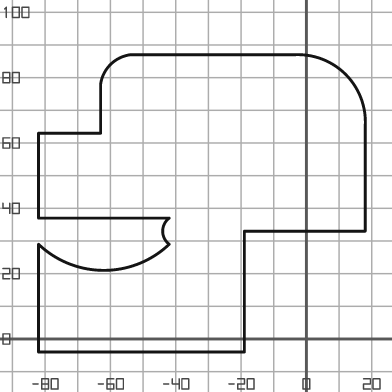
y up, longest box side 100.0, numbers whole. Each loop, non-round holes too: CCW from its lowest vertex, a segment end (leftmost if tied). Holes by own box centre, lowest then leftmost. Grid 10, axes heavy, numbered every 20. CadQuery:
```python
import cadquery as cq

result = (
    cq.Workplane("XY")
    .moveTo(-82.0, -4.0)
    .lineTo(-19.0, -4.0)
    .lineTo(-19.0, 33.0)
    .lineTo(18.0, 33.0)
    .lineTo(18.0, 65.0)
    .threePointArc((12.0, 81.0), (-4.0, 87.0))
    .lineTo(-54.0, 87.0)
    .threePointArc((-60.0, 84.0), (-63.0, 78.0))
    .lineTo(-63.0, 63.0)
    .lineTo(-82.0, 63.0)
    .lineTo(-82.0, 37.0)
    .lineTo(-42.0, 37.0)
    .threePointArc((-44.0, 33.0), (-42.0, 29.0))
    .threePointArc((-62.0, 21.0), (-82.0, 29.0))
    .close()
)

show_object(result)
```